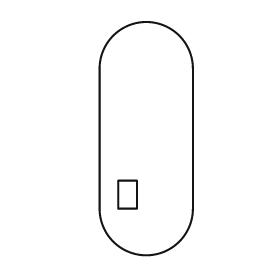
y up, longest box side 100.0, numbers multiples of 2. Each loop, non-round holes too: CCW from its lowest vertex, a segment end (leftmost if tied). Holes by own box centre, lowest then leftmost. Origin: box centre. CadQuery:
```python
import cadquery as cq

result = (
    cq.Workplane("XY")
    .moveTo(-20.0, -30.0)
    .threePointArc((0.0, -50.0), (20.0, -30.0))
    .lineTo(20.0, 30.0)
    .threePointArc((0.0, 50.0), (-20.0, 30.0))
    .close()
    .moveTo(-12.0, -30.0)
    .lineTo(-4.0, -30.0)
    .lineTo(-4.0, -18.0)
    .lineTo(-12.0, -18.0)
    .close()
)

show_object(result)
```